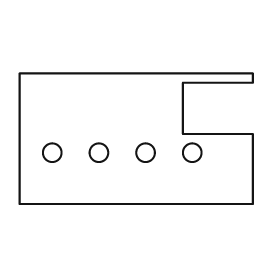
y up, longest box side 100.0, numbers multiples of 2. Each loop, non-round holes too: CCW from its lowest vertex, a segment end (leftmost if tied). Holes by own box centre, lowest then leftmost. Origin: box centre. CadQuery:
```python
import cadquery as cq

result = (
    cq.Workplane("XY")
    .moveTo(-50.0, -28.0)
    .lineTo(50.0, -28.0)
    .lineTo(50.0, 2.0)
    .lineTo(20.0, 2.0)
    .lineTo(20.0, 24.0)
    .lineTo(50.0, 24.0)
    .lineTo(50.0, 28.0)
    .lineTo(-50.0, 28.0)
    .close()
    .moveTo(-36.0, -6.0)
    .circle(4.0)
    .moveTo(-16.0, -6.0)
    .circle(4.0)
    .moveTo(4.0, -6.0)
    .circle(4.0)
    .moveTo(24.0, -6.0)
    .circle(4.0)
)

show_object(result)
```